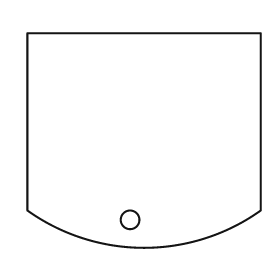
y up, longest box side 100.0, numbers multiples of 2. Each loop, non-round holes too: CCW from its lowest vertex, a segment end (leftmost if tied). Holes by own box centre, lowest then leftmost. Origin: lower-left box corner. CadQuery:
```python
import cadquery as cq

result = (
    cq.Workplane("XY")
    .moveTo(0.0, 16.0)
    .threePointArc((50.0, 0.0), (100.0, 16.0))
    .lineTo(100.0, 92.0)
    .lineTo(0.0, 92.0)
    .close()
    .moveTo(44.0, 12.0)
    .circle(4.0)
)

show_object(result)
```